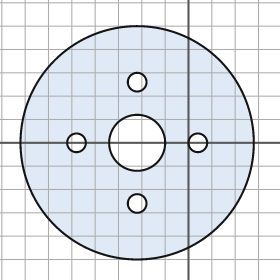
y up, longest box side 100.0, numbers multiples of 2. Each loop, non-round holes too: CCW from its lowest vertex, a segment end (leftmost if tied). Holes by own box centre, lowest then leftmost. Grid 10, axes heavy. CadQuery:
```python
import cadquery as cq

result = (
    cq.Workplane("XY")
    .moveTo(-22.0, 0.0)
    .circle(50.0)
    .moveTo(-22.0, -26.0)
    .circle(4.0)
    .moveTo(-48.0, 0.0)
    .circle(4.0)
    .moveTo(-22.0, 0.0)
    .circle(12.0)
    .moveTo(4.0, 0.0)
    .circle(4.0)
    .moveTo(-22.0, 26.0)
    .circle(4.0)
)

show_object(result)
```